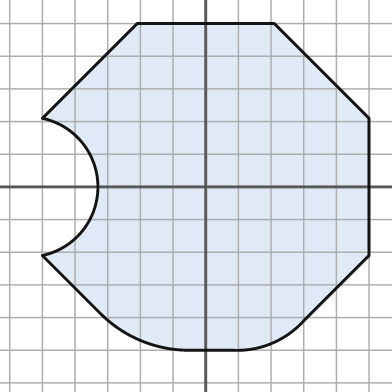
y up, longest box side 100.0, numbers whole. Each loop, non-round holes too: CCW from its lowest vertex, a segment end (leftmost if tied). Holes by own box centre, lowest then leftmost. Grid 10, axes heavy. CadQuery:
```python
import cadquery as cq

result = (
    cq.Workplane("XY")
    .moveTo(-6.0, -50.0)
    .lineTo(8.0, -50.0)
    .threePointArc((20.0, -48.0), (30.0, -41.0))
    .lineTo(50.0, -21.0)
    .lineTo(50.0, 21.0)
    .lineTo(21.0, 50.0)
    .lineTo(-21.0, 50.0)
    .lineTo(-50.0, 21.0)
    .threePointArc((-33.0, 0.0), (-50.0, -21.0))
    .lineTo(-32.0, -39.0)
    .threePointArc((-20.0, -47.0), (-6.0, -50.0))
    .close()
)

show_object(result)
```